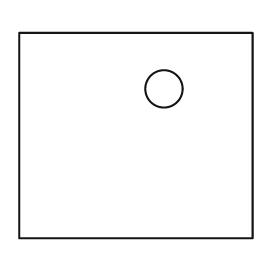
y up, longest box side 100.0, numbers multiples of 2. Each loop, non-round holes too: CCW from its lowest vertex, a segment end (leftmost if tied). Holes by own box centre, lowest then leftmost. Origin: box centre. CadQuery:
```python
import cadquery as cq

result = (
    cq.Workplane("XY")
    .moveTo(-50.0, -44.0)
    .lineTo(50.0, -44.0)
    .lineTo(50.0, 44.0)
    .lineTo(-50.0, 44.0)
    .close()
    .moveTo(12.0, 20.0)
    .circle(8.0)
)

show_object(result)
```